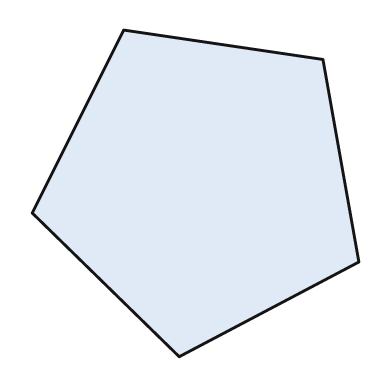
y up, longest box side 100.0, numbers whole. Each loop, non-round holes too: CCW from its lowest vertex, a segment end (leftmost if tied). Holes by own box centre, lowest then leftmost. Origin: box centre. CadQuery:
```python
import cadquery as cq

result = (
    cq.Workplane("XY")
    .moveTo(-5.0, -50.0)
    .lineTo(50.0, -21.0)
    .lineTo(39.0, 41.0)
    .lineTo(-22.0, 50.0)
    .lineTo(-50.0, -6.0)
    .close()
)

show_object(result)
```